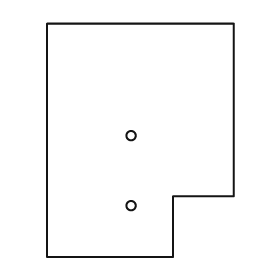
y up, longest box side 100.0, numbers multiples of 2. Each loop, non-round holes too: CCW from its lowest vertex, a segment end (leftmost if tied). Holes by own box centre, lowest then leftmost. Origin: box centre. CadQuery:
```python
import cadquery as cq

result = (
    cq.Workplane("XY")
    .moveTo(-40.0, -50.0)
    .lineTo(14.0, -50.0)
    .lineTo(14.0, -24.0)
    .lineTo(40.0, -24.0)
    .lineTo(40.0, 50.0)
    .lineTo(-40.0, 50.0)
    .close()
    .moveTo(-4.0, -28.0)
    .circle(2.0)
    .moveTo(-4.0, 2.0)
    .circle(2.0)
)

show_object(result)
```